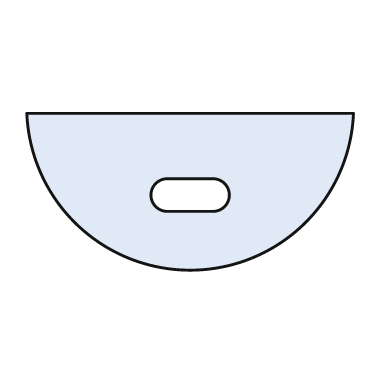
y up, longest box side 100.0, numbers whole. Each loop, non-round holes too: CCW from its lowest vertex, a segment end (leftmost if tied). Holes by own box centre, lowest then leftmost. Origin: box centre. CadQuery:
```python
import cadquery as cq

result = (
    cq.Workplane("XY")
    .moveTo(-50.0, 24.0)
    .threePointArc((0.0, -24.0), (50.0, 24.0))
    .close()
    .moveTo(-7.0, -6.0)
    .lineTo(7.0, -6.0)
    .threePointArc((12.0, -1.0), (7.0, 4.0))
    .lineTo(-7.0, 4.0)
    .threePointArc((-12.0, -1.0), (-7.0, -6.0))
    .close()
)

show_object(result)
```